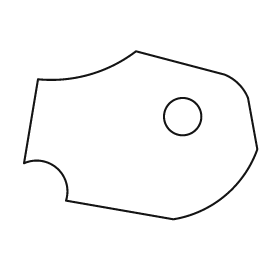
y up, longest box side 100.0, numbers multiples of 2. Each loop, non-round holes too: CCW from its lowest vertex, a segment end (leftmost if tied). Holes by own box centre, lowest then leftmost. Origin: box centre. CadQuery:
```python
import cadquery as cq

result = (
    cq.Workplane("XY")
    .moveTo(14.0, -36.0)
    .threePointArc((36.0, -26.0), (50.0, -6.0))
    .lineTo(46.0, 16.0)
    .threePointArc((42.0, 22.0), (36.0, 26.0))
    .lineTo(-2.0, 36.0)
    .threePointArc((-22.0, 26.0), (-44.0, 24.0))
    .lineTo(-50.0, -12.0)
    .threePointArc((-36.0, -14.0), (-32.0, -28.0))
    .close()
    .moveTo(18.0, 8.0)
    .circle(8.0)
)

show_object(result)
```